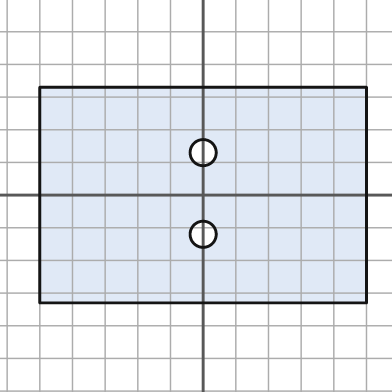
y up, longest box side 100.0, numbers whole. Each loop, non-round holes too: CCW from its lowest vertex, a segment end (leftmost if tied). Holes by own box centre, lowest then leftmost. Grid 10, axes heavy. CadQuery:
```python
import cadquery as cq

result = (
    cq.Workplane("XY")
    .moveTo(-50.0, -33.0)
    .lineTo(50.0, -33.0)
    .lineTo(50.0, 33.0)
    .lineTo(-50.0, 33.0)
    .close()
    .moveTo(0.0, -12.0)
    .circle(4.0)
    .moveTo(0.0, 13.0)
    .circle(4.0)
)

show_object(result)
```